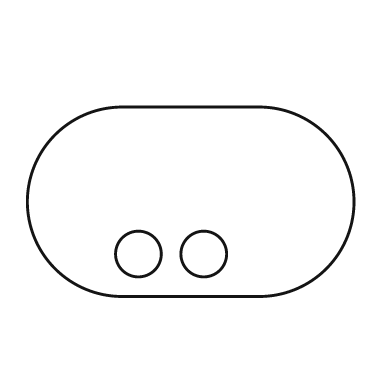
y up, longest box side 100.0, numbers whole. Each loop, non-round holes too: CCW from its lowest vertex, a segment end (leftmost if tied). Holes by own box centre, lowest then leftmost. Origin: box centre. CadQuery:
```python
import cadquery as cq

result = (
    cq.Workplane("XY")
    .moveTo(-21.0, -29.0)
    .lineTo(21.0, -29.0)
    .threePointArc((50.0, 0.0), (21.0, 29.0))
    .lineTo(-21.0, 29.0)
    .threePointArc((-50.0, 0.0), (-21.0, -29.0))
    .close()
    .moveTo(-16.0, -16.0)
    .circle(7.0)
    .moveTo(4.0, -16.0)
    .circle(7.0)
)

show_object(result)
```